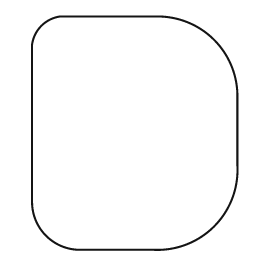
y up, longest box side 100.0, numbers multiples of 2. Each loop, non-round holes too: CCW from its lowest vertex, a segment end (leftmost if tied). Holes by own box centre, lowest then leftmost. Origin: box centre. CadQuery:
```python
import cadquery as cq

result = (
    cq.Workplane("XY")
    .moveTo(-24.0, -50.0)
    .lineTo(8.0, -50.0)
    .threePointArc((34.0, -40.0), (44.0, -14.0))
    .lineTo(44.0, 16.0)
    .threePointArc((34.0, 40.0), (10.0, 50.0))
    .lineTo(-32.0, 50.0)
    .threePointArc((-40.0, 46.0), (-44.0, 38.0))
    .lineTo(-44.0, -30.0)
    .threePointArc((-38.0, -44.0), (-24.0, -50.0))
    .close()
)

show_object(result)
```